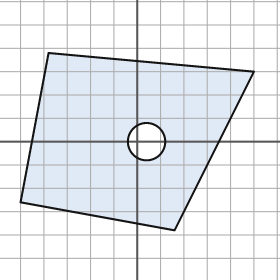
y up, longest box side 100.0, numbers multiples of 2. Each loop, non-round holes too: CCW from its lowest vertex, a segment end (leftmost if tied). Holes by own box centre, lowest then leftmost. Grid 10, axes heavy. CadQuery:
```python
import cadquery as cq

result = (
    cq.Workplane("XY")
    .moveTo(16.0, -38.0)
    .lineTo(50.0, 30.0)
    .lineTo(-38.0, 38.0)
    .lineTo(-50.0, -26.0)
    .close()
    .moveTo(4.0, 0.0)
    .circle(8.0)
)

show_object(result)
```